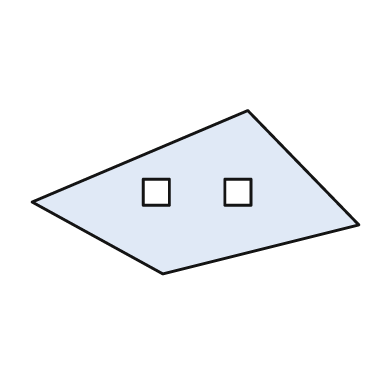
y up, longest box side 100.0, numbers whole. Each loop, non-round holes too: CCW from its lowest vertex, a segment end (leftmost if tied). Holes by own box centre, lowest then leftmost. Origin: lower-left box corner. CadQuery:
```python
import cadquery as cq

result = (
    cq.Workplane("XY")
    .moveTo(40.0, 0.0)
    .lineTo(100.0, 15.0)
    .lineTo(66.0, 50.0)
    .lineTo(0.0, 22.0)
    .close()
    .moveTo(34.0, 21.0)
    .lineTo(42.0, 21.0)
    .lineTo(42.0, 29.0)
    .lineTo(34.0, 29.0)
    .close()
    .moveTo(59.0, 21.0)
    .lineTo(67.0, 21.0)
    .lineTo(67.0, 29.0)
    .lineTo(59.0, 29.0)
    .close()
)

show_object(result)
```